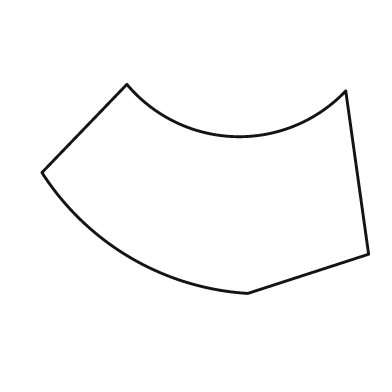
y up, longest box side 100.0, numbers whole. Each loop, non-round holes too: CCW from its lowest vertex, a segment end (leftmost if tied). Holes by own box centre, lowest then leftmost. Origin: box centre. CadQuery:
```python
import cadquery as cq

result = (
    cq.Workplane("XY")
    .moveTo(13.0, -32.0)
    .lineTo(50.0, -20.0)
    .lineTo(43.0, 30.0)
    .threePointArc((9.0, 16.0), (-24.0, 32.0))
    .lineTo(-50.0, 5.0)
    .threePointArc((-23.0, -21.0), (13.0, -32.0))
    .close()
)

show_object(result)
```